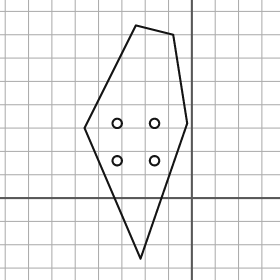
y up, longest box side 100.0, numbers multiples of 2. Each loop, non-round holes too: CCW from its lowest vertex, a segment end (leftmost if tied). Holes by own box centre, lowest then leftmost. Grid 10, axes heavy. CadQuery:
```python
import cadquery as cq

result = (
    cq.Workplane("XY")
    .moveTo(-22.0, -26.0)
    .lineTo(-2.0, 32.0)
    .lineTo(-8.0, 70.0)
    .lineTo(-24.0, 74.0)
    .lineTo(-46.0, 30.0)
    .close()
    .moveTo(-32.0, 16.0)
    .circle(2.0)
    .moveTo(-16.0, 16.0)
    .circle(2.0)
    .moveTo(-32.0, 32.0)
    .circle(2.0)
    .moveTo(-16.0, 32.0)
    .circle(2.0)
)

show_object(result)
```